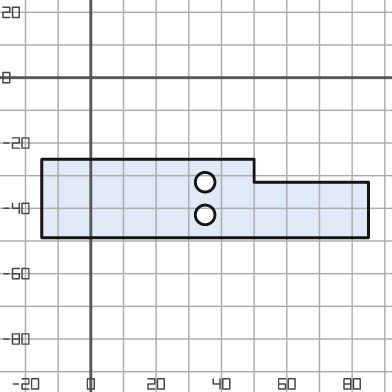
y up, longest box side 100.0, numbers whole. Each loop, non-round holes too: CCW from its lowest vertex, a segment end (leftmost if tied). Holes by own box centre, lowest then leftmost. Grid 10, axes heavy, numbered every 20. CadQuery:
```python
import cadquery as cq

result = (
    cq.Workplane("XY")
    .moveTo(-15.0, -49.0)
    .lineTo(85.0, -49.0)
    .lineTo(85.0, -32.0)
    .lineTo(50.0, -32.0)
    .lineTo(50.0, -25.0)
    .lineTo(-15.0, -25.0)
    .close()
    .moveTo(35.0, -42.0)
    .circle(3.0)
    .moveTo(35.0, -32.0)
    .circle(3.0)
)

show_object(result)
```